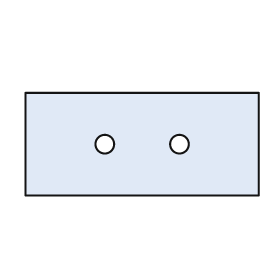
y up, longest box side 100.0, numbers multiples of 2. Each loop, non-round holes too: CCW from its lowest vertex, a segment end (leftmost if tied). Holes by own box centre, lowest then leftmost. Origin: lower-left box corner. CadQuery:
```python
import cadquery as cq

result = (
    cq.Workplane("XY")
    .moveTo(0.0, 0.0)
    .lineTo(100.0, 0.0)
    .lineTo(100.0, 44.0)
    .lineTo(0.0, 44.0)
    .close()
    .moveTo(34.0, 22.0)
    .circle(4.0)
    .moveTo(66.0, 22.0)
    .circle(4.0)
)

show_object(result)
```